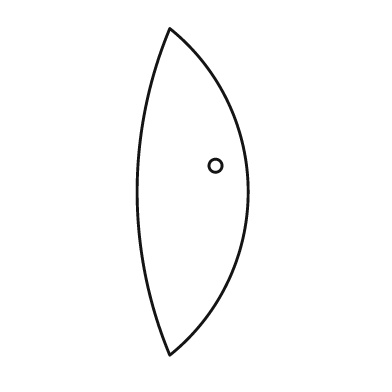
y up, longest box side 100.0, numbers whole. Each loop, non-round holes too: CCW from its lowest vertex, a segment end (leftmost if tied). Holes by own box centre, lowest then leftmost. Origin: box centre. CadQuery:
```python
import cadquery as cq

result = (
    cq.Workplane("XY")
    .moveTo(-7.0, -50.0)
    .threePointArc((17.0, 0.0), (-7.0, 50.0))
    .threePointArc((-17.0, 0.0), (-7.0, -50.0))
    .close()
    .moveTo(7.0, 8.0)
    .circle(2.0)
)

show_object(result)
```